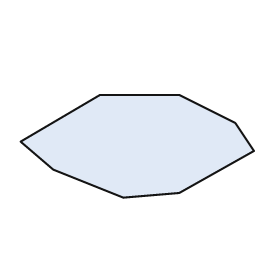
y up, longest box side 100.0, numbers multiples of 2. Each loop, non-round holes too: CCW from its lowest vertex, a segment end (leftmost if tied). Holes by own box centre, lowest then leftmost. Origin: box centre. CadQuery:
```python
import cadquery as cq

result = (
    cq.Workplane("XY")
    .moveTo(-6.0, -22.0)
    .lineTo(18.0, -20.0)
    .lineTo(50.0, -2.0)
    .lineTo(42.0, 10.0)
    .lineTo(18.0, 22.0)
    .lineTo(-16.0, 22.0)
    .lineTo(-50.0, 2.0)
    .lineTo(-36.0, -10.0)
    .close()
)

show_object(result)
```